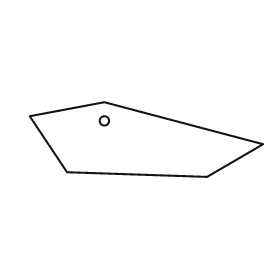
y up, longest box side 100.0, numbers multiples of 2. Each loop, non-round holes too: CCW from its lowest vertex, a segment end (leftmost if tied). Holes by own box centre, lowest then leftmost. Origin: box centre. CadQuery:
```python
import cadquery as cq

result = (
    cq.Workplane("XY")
    .moveTo(26.0, -16.0)
    .lineTo(50.0, -2.0)
    .lineTo(-18.0, 16.0)
    .lineTo(-50.0, 10.0)
    .lineTo(-34.0, -14.0)
    .close()
    .moveTo(-18.0, 8.0)
    .circle(2.0)
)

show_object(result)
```